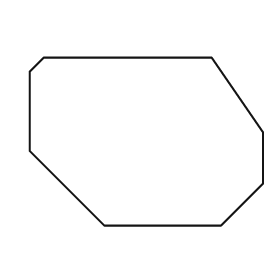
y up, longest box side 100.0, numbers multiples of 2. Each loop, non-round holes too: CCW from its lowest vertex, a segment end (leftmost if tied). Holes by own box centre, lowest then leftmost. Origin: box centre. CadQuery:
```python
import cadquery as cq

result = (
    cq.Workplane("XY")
    .moveTo(-18.0, -36.0)
    .lineTo(32.0, -36.0)
    .lineTo(50.0, -18.0)
    .lineTo(50.0, 4.0)
    .lineTo(28.0, 36.0)
    .lineTo(-44.0, 36.0)
    .lineTo(-50.0, 30.0)
    .lineTo(-50.0, -4.0)
    .close()
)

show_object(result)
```